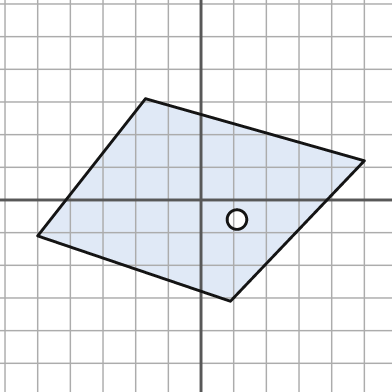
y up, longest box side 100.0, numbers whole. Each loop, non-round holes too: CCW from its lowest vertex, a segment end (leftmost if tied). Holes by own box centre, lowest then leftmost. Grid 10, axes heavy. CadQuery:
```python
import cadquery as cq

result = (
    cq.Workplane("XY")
    .moveTo(9.0, -31.0)
    .lineTo(50.0, 12.0)
    .lineTo(-17.0, 31.0)
    .lineTo(-50.0, -11.0)
    .close()
    .moveTo(11.0, -6.0)
    .circle(3.0)
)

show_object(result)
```